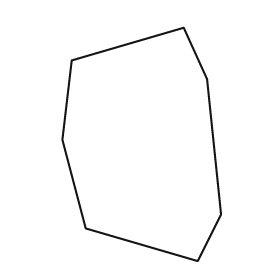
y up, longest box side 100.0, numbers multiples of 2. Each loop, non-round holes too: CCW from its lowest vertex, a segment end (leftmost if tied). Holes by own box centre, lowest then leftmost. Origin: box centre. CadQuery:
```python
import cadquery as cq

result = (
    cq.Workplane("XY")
    .moveTo(24.0, -50.0)
    .lineTo(34.0, -30.0)
    .lineTo(28.0, 28.0)
    .lineTo(18.0, 50.0)
    .lineTo(-30.0, 36.0)
    .lineTo(-34.0, 2.0)
    .lineTo(-24.0, -36.0)
    .close()
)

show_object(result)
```